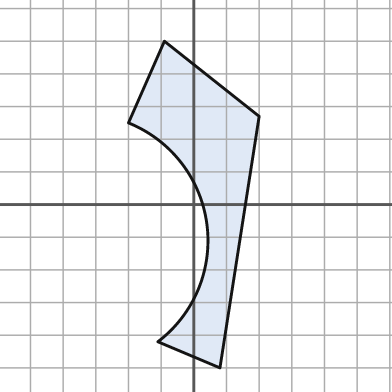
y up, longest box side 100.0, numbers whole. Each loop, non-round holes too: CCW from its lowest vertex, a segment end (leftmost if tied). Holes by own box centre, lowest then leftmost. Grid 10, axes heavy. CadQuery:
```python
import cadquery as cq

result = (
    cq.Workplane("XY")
    .moveTo(8.0, -50.0)
    .lineTo(20.0, 27.0)
    .lineTo(-9.0, 50.0)
    .lineTo(-20.0, 25.0)
    .threePointArc((4.0, -6.0), (-11.0, -42.0))
    .close()
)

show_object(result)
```